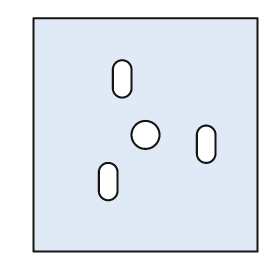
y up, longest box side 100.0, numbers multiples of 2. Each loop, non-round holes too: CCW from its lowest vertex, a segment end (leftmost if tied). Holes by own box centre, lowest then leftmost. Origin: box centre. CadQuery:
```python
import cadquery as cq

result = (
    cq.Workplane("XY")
    .moveTo(-48.0, -50.0)
    .lineTo(48.0, -50.0)
    .lineTo(48.0, 50.0)
    .lineTo(-48.0, 50.0)
    .close()
    .moveTo(-20.0, -24.0)
    .threePointArc((-16.0, -28.0), (-12.0, -24.0))
    .lineTo(-12.0, -16.0)
    .threePointArc((-16.0, -12.0), (-20.0, -16.0))
    .close()
    .moveTo(22.0, -8.0)
    .threePointArc((26.0, -12.0), (30.0, -8.0))
    .lineTo(30.0, 0.0)
    .threePointArc((26.0, 4.0), (22.0, 0.0))
    .close()
    .moveTo(0.0, 0.0)
    .circle(6.0)
    .moveTo(-14.0, 20.0)
    .threePointArc((-10.0, 16.0), (-6.0, 20.0))
    .lineTo(-6.0, 28.0)
    .threePointArc((-10.0, 32.0), (-14.0, 28.0))
    .close()
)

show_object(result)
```